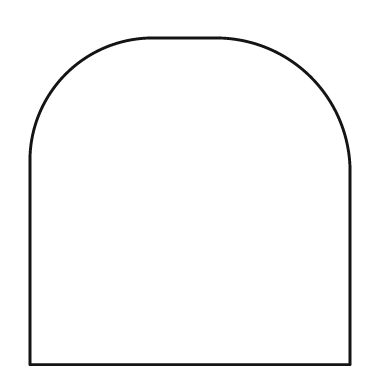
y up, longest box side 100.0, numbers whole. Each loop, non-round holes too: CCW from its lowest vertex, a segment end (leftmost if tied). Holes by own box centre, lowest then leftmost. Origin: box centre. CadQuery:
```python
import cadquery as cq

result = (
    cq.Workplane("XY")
    .moveTo(-49.0, -50.0)
    .lineTo(49.0, -50.0)
    .lineTo(49.0, 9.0)
    .threePointArc((37.0, 38.0), (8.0, 50.0))
    .lineTo(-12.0, 50.0)
    .threePointArc((-38.0, 39.0), (-49.0, 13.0))
    .close()
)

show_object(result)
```